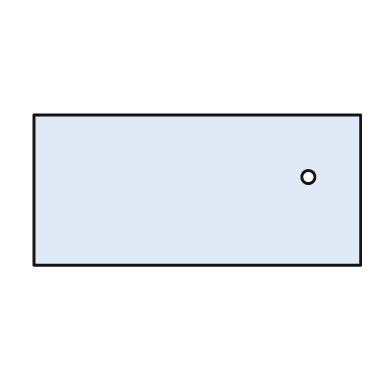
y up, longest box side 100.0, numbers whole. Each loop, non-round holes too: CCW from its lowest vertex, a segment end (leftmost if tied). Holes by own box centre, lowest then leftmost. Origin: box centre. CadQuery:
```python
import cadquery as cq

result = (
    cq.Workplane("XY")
    .moveTo(-50.0, -23.0)
    .lineTo(50.0, -23.0)
    .lineTo(50.0, 23.0)
    .lineTo(-50.0, 23.0)
    .close()
    .moveTo(34.0, 4.0)
    .circle(2.0)
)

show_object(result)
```